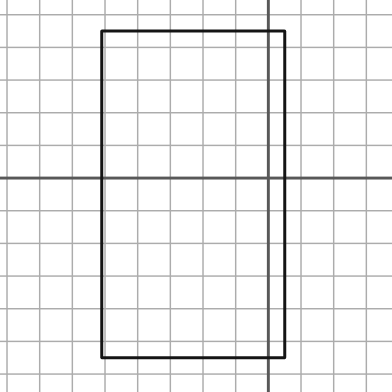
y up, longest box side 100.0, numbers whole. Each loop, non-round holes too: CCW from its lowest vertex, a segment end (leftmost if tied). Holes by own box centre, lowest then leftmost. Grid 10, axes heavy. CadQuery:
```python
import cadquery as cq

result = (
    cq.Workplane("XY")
    .moveTo(-51.0, -55.0)
    .lineTo(5.0, -55.0)
    .lineTo(5.0, 45.0)
    .lineTo(-51.0, 45.0)
    .close()
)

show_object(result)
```